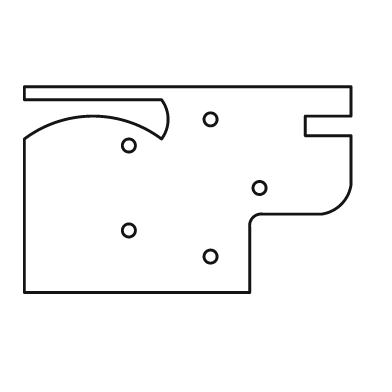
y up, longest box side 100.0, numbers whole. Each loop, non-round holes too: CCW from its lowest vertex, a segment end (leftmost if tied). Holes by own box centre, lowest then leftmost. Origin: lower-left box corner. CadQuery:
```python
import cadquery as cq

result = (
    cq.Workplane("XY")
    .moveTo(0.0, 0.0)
    .lineTo(69.0, 0.0)
    .lineTo(69.0, 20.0)
    .threePointArc((70.0, 23.0), (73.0, 24.0))
    .lineTo(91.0, 24.0)
    .threePointArc((97.0, 27.0), (100.0, 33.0))
    .lineTo(100.0, 48.0)
    .lineTo(86.0, 48.0)
    .lineTo(86.0, 54.0)
    .lineTo(100.0, 54.0)
    .lineTo(100.0, 63.0)
    .lineTo(0.0, 63.0)
    .lineTo(0.0, 59.0)
    .lineTo(42.0, 59.0)
    .threePointArc((44.0, 53.0), (42.0, 47.0))
    .threePointArc((21.0, 54.0), (0.0, 47.0))
    .close()
    .moveTo(57.0, 11.0)
    .circle(2.0)
    .moveTo(32.0, 19.0)
    .circle(2.0)
    .moveTo(72.0, 32.0)
    .circle(2.0)
    .moveTo(32.0, 45.0)
    .circle(2.0)
    .moveTo(57.0, 53.0)
    .circle(2.0)
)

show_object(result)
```